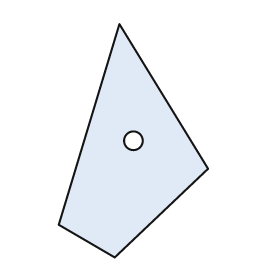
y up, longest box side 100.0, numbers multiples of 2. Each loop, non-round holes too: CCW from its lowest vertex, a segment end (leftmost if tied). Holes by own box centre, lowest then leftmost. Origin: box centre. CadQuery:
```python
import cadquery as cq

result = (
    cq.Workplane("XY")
    .moveTo(-8.0, -50.0)
    .lineTo(32.0, -12.0)
    .lineTo(-6.0, 50.0)
    .lineTo(-32.0, -36.0)
    .close()
    .moveTo(0.0, 0.0)
    .circle(4.0)
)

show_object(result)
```